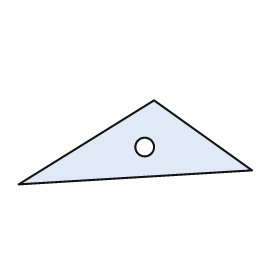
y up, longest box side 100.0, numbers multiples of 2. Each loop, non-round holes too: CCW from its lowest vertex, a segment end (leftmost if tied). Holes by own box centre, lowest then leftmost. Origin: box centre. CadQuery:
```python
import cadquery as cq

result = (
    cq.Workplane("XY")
    .moveTo(-50.0, -18.0)
    .lineTo(50.0, -12.0)
    .lineTo(8.0, 18.0)
    .close()
    .moveTo(4.0, -2.0)
    .circle(4.0)
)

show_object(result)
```